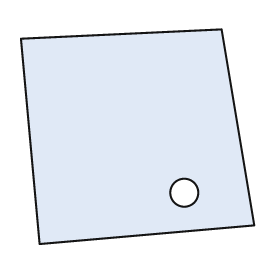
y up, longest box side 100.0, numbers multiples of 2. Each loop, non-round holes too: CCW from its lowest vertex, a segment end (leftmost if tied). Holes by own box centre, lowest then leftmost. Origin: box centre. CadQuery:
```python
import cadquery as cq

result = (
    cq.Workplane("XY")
    .moveTo(-42.0, -46.0)
    .lineTo(50.0, -38.0)
    .lineTo(36.0, 46.0)
    .lineTo(-50.0, 42.0)
    .close()
    .moveTo(20.0, -24.0)
    .circle(6.0)
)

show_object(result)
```